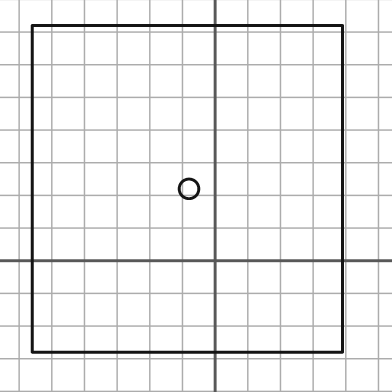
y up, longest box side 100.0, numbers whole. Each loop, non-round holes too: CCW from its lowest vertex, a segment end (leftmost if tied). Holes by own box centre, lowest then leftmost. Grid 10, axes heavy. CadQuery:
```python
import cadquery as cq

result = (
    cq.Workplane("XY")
    .moveTo(-56.0, -28.0)
    .lineTo(39.0, -28.0)
    .lineTo(39.0, 72.0)
    .lineTo(-56.0, 72.0)
    .close()
    .moveTo(-8.0, 22.0)
    .circle(3.0)
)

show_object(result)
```